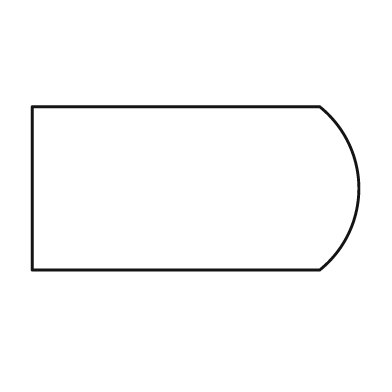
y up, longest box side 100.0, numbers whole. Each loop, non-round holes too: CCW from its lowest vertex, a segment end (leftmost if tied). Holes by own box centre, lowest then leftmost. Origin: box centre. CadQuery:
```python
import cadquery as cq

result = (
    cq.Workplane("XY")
    .moveTo(-50.0, -25.0)
    .lineTo(38.0, -25.0)
    .threePointArc((50.0, 0.0), (38.0, 25.0))
    .lineTo(-50.0, 25.0)
    .close()
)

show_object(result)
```